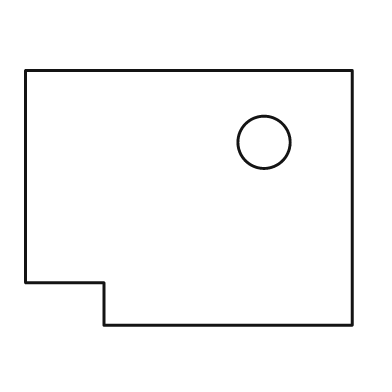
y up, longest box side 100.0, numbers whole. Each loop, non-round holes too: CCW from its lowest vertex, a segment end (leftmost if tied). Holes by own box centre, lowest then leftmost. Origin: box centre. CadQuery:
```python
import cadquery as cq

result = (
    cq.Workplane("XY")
    .moveTo(-26.0, -39.0)
    .lineTo(50.0, -39.0)
    .lineTo(50.0, 39.0)
    .lineTo(-50.0, 39.0)
    .lineTo(-50.0, -26.0)
    .lineTo(-26.0, -26.0)
    .close()
    .moveTo(23.0, 17.0)
    .circle(8.0)
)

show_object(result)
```